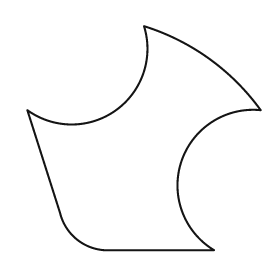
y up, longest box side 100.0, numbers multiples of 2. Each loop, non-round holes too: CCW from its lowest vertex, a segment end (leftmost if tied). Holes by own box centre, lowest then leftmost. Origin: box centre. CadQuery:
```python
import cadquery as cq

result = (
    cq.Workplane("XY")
    .moveTo(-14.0, -48.0)
    .lineTo(30.0, -48.0)
    .threePointArc((16.0, -10.0), (50.0, 12.0))
    .threePointArc((28.0, 34.0), (0.0, 48.0))
    .threePointArc((-12.0, 12.0), (-50.0, 12.0))
    .lineTo(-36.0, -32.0)
    .threePointArc((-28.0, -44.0), (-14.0, -48.0))
    .close()
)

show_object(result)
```